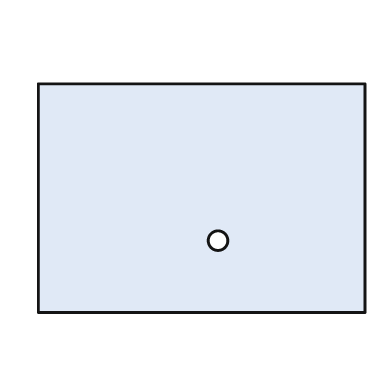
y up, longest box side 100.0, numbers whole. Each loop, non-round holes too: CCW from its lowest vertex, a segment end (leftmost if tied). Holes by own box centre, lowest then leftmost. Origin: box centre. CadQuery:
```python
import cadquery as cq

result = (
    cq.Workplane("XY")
    .moveTo(-50.0, -35.0)
    .lineTo(50.0, -35.0)
    .lineTo(50.0, 35.0)
    .lineTo(-50.0, 35.0)
    .close()
    .moveTo(5.0, -13.0)
    .circle(3.0)
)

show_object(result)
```